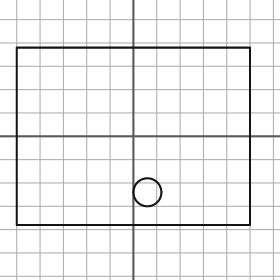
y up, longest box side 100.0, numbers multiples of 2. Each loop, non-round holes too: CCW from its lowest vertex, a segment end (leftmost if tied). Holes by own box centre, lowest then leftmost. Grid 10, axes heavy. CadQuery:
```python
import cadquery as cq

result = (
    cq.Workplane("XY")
    .moveTo(-50.0, -38.0)
    .lineTo(50.0, -38.0)
    .lineTo(50.0, 38.0)
    .lineTo(-50.0, 38.0)
    .close()
    .moveTo(6.0, -24.0)
    .circle(6.0)
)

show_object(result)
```